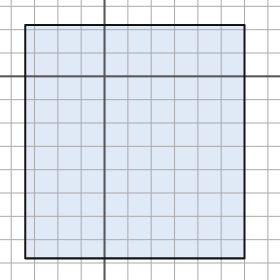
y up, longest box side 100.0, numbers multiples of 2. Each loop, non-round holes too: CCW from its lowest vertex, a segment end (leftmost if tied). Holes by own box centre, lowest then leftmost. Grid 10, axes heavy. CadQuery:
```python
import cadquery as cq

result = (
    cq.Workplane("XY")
    .moveTo(-34.0, -78.0)
    .lineTo(60.0, -78.0)
    .lineTo(60.0, 22.0)
    .lineTo(-34.0, 22.0)
    .close()
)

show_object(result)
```